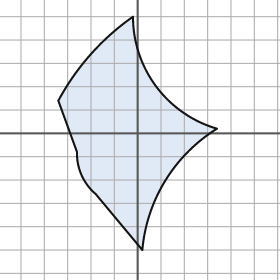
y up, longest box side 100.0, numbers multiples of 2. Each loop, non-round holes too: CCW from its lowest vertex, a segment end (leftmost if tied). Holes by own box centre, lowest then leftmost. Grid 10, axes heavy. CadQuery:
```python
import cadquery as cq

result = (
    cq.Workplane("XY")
    .moveTo(2.0, -50.0)
    .threePointArc((12.0, -20.0), (34.0, 2.0))
    .threePointArc((8.0, 20.0), (-2.0, 50.0))
    .threePointArc((-20.0, 34.0), (-34.0, 14.0))
    .lineTo(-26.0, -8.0)
    .threePointArc((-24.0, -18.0), (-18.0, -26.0))
    .close()
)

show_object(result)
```